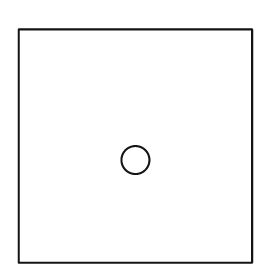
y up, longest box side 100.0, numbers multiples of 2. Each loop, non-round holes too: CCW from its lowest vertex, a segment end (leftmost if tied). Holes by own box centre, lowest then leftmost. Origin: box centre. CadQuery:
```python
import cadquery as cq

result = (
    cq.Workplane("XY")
    .moveTo(-50.0, -50.0)
    .lineTo(50.0, -50.0)
    .lineTo(50.0, 50.0)
    .lineTo(-50.0, 50.0)
    .close()
    .moveTo(0.0, -6.0)
    .circle(6.0)
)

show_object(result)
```